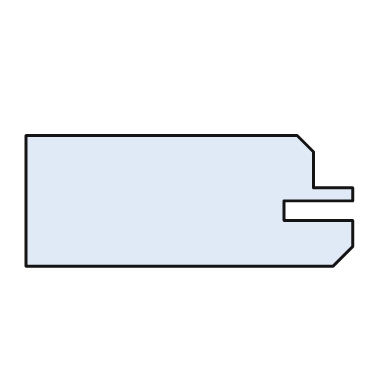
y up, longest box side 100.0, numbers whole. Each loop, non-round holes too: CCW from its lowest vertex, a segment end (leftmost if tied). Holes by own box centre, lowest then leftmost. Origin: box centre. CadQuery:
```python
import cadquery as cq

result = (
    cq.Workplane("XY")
    .moveTo(-50.0, -20.0)
    .lineTo(44.0, -20.0)
    .lineTo(50.0, -14.0)
    .lineTo(50.0, -6.0)
    .lineTo(29.0, -6.0)
    .lineTo(29.0, 0.0)
    .lineTo(50.0, 0.0)
    .lineTo(50.0, 4.0)
    .lineTo(38.0, 4.0)
    .lineTo(38.0, 15.0)
    .lineTo(33.0, 20.0)
    .lineTo(-50.0, 20.0)
    .close()
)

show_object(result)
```